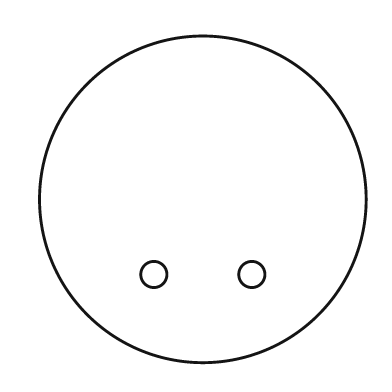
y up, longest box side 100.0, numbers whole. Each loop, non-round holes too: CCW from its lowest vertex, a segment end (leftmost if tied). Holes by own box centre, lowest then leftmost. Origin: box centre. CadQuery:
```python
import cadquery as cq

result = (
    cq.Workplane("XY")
    .moveTo(0.0, 0.0)
    .circle(50.0)
    .moveTo(-15.0, -23.0)
    .circle(4.0)
    .moveTo(15.0, -23.0)
    .circle(4.0)
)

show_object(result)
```